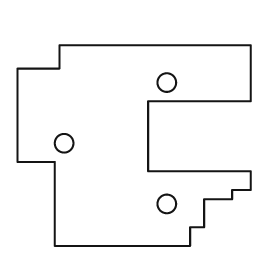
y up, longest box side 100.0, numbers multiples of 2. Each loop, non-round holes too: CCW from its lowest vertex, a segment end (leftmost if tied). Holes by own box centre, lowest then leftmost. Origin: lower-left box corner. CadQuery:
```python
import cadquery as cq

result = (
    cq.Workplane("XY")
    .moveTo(16.0, 0.0)
    .lineTo(74.0, 0.0)
    .lineTo(74.0, 8.0)
    .lineTo(80.0, 8.0)
    .lineTo(80.0, 20.0)
    .lineTo(92.0, 20.0)
    .lineTo(92.0, 24.0)
    .lineTo(100.0, 24.0)
    .lineTo(100.0, 32.0)
    .lineTo(56.0, 32.0)
    .lineTo(56.0, 62.0)
    .lineTo(100.0, 62.0)
    .lineTo(100.0, 86.0)
    .lineTo(18.0, 86.0)
    .lineTo(18.0, 76.0)
    .lineTo(0.0, 76.0)
    .lineTo(0.0, 36.0)
    .lineTo(16.0, 36.0)
    .close()
    .moveTo(64.0, 18.0)
    .circle(4.0)
    .moveTo(20.0, 44.0)
    .circle(4.0)
    .moveTo(64.0, 70.0)
    .circle(4.0)
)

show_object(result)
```